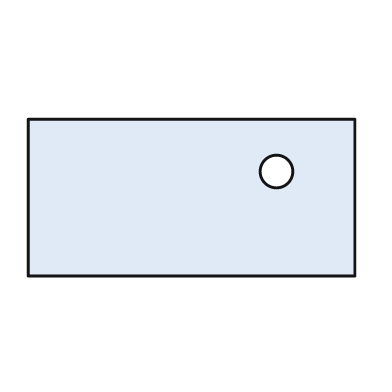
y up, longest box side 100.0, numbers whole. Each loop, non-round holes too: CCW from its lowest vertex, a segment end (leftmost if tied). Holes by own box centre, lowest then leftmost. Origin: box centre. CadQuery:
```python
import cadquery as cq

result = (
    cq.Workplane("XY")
    .moveTo(-50.0, -24.0)
    .lineTo(50.0, -24.0)
    .lineTo(50.0, 24.0)
    .lineTo(-50.0, 24.0)
    .close()
    .moveTo(26.0, 8.0)
    .circle(5.0)
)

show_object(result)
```